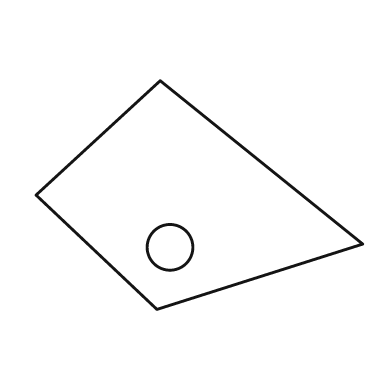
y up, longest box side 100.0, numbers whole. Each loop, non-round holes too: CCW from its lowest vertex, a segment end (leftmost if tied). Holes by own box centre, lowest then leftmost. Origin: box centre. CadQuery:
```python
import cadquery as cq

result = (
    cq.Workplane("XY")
    .moveTo(-13.0, -35.0)
    .lineTo(50.0, -15.0)
    .lineTo(-12.0, 35.0)
    .lineTo(-50.0, 0.0)
    .close()
    .moveTo(-9.0, -16.0)
    .circle(7.0)
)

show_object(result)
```